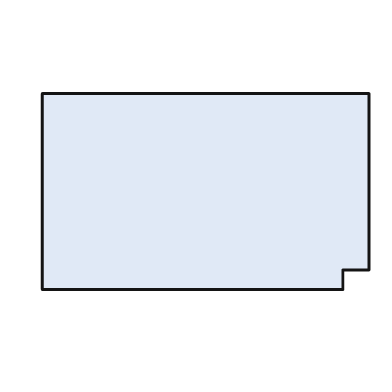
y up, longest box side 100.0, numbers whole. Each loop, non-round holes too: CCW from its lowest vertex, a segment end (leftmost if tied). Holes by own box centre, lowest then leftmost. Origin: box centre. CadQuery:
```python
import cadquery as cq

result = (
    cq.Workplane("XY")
    .moveTo(-50.0, -30.0)
    .lineTo(42.0, -30.0)
    .lineTo(42.0, -24.0)
    .lineTo(50.0, -24.0)
    .lineTo(50.0, 30.0)
    .lineTo(-50.0, 30.0)
    .close()
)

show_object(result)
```